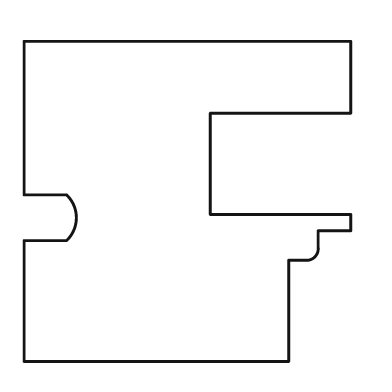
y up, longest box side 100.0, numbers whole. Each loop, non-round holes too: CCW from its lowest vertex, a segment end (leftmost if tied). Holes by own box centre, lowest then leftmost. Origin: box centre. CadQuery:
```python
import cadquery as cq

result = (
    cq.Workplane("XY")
    .moveTo(-50.0, -49.0)
    .lineTo(31.0, -49.0)
    .lineTo(31.0, -18.0)
    .lineTo(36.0, -18.0)
    .threePointArc((39.0, -17.0), (40.0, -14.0))
    .lineTo(40.0, -9.0)
    .lineTo(50.0, -9.0)
    .lineTo(50.0, -4.0)
    .lineTo(7.0, -4.0)
    .lineTo(7.0, 27.0)
    .lineTo(50.0, 27.0)
    .lineTo(50.0, 49.0)
    .lineTo(-50.0, 49.0)
    .lineTo(-50.0, 2.0)
    .lineTo(-37.0, 2.0)
    .threePointArc((-34.0, -5.0), (-37.0, -12.0))
    .lineTo(-50.0, -12.0)
    .close()
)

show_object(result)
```